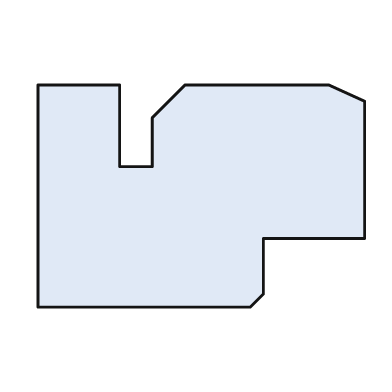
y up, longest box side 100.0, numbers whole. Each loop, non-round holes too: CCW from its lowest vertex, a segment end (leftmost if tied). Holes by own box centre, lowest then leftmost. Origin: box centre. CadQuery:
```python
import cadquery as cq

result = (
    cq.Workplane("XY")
    .moveTo(-50.0, -34.0)
    .lineTo(15.0, -34.0)
    .lineTo(19.0, -30.0)
    .lineTo(19.0, -13.0)
    .lineTo(50.0, -13.0)
    .lineTo(50.0, 29.0)
    .lineTo(39.0, 34.0)
    .lineTo(-5.0, 34.0)
    .lineTo(-15.0, 24.0)
    .lineTo(-15.0, 9.0)
    .lineTo(-25.0, 9.0)
    .lineTo(-25.0, 34.0)
    .lineTo(-50.0, 34.0)
    .close()
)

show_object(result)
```